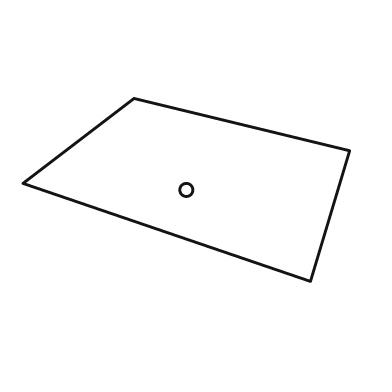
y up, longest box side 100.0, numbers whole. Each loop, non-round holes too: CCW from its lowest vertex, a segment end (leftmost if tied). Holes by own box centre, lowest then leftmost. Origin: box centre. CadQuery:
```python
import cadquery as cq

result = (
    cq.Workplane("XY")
    .moveTo(38.0, -28.0)
    .lineTo(50.0, 12.0)
    .lineTo(-16.0, 28.0)
    .lineTo(-50.0, 2.0)
    .close()
    .moveTo(0.0, 0.0)
    .circle(2.0)
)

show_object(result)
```